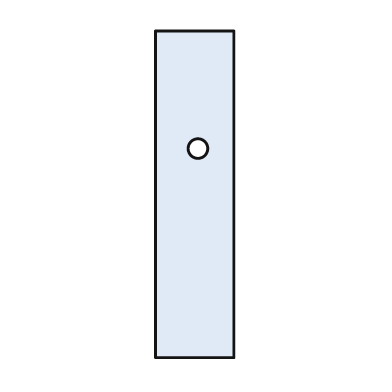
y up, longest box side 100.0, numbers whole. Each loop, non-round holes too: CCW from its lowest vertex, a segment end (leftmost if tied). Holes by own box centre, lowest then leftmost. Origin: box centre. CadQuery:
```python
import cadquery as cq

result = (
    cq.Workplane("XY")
    .moveTo(-12.0, -50.0)
    .lineTo(12.0, -50.0)
    .lineTo(12.0, 50.0)
    .lineTo(-12.0, 50.0)
    .close()
    .moveTo(1.0, 14.0)
    .circle(3.0)
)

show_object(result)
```